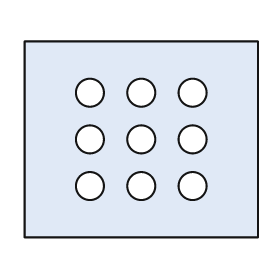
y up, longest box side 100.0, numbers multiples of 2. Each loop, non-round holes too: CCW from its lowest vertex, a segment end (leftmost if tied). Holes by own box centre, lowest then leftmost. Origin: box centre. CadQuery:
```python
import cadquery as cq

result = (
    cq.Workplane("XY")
    .moveTo(-50.0, -42.0)
    .lineTo(50.0, -42.0)
    .lineTo(50.0, 42.0)
    .lineTo(-50.0, 42.0)
    .close()
    .moveTo(-22.0, -20.0)
    .circle(6.0)
    .moveTo(0.0, -20.0)
    .circle(6.0)
    .moveTo(22.0, -20.0)
    .circle(6.0)
    .moveTo(-22.0, 0.0)
    .circle(6.0)
    .moveTo(0.0, 0.0)
    .circle(6.0)
    .moveTo(22.0, 0.0)
    .circle(6.0)
    .moveTo(-22.0, 20.0)
    .circle(6.0)
    .moveTo(0.0, 20.0)
    .circle(6.0)
    .moveTo(22.0, 20.0)
    .circle(6.0)
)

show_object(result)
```